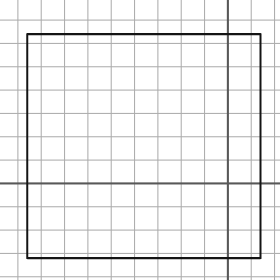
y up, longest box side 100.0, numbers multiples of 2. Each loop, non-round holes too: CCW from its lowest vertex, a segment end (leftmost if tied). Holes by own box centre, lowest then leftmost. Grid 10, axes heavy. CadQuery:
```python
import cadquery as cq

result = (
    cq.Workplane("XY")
    .moveTo(-86.0, -32.0)
    .lineTo(14.0, -32.0)
    .lineTo(14.0, 64.0)
    .lineTo(-86.0, 64.0)
    .close()
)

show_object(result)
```